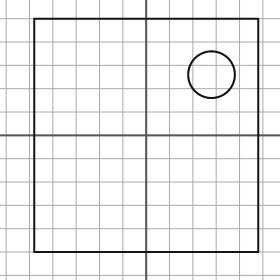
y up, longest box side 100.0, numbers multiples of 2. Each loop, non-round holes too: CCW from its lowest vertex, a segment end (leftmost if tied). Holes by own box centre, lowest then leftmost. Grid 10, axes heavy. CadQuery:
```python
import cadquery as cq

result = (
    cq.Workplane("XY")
    .moveTo(-48.0, -50.0)
    .lineTo(48.0, -50.0)
    .lineTo(48.0, 50.0)
    .lineTo(-48.0, 50.0)
    .close()
    .moveTo(28.0, 26.0)
    .circle(10.0)
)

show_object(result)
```